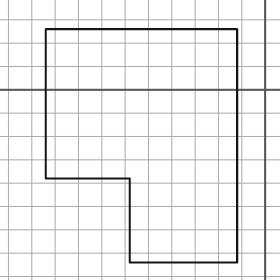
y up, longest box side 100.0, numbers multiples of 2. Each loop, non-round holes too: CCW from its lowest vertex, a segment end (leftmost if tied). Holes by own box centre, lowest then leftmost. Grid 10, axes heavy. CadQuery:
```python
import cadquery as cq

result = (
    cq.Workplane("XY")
    .moveTo(-58.0, -74.0)
    .lineTo(-12.0, -74.0)
    .lineTo(-12.0, 26.0)
    .lineTo(-94.0, 26.0)
    .lineTo(-94.0, -38.0)
    .lineTo(-58.0, -38.0)
    .close()
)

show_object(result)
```